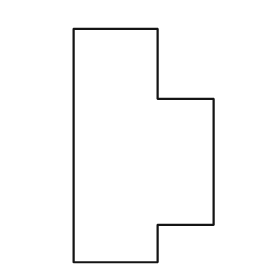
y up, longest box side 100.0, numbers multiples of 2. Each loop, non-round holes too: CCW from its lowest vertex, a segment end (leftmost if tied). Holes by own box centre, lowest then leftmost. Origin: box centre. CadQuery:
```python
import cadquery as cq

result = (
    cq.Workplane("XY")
    .moveTo(-30.0, -50.0)
    .lineTo(6.0, -50.0)
    .lineTo(6.0, -34.0)
    .lineTo(30.0, -34.0)
    .lineTo(30.0, 20.0)
    .lineTo(6.0, 20.0)
    .lineTo(6.0, 50.0)
    .lineTo(-30.0, 50.0)
    .close()
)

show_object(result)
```